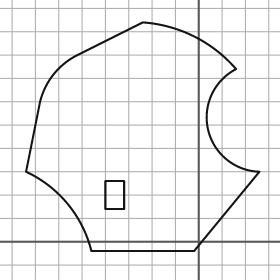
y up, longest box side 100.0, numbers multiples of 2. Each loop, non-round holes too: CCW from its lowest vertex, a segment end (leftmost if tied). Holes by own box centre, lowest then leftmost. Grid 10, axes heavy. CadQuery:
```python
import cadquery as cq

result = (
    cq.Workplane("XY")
    .moveTo(-46.0, -4.0)
    .lineTo(-2.0, -4.0)
    .lineTo(26.0, 30.0)
    .threePointArc((4.0, 48.0), (16.0, 74.0))
    .threePointArc((-2.0, 88.0), (-24.0, 94.0))
    .lineTo(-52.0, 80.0)
    .threePointArc((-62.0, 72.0), (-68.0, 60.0))
    .lineTo(-74.0, 30.0)
    .threePointArc((-56.0, 16.0), (-46.0, -4.0))
    .close()
    .moveTo(-40.0, 14.0)
    .lineTo(-32.0, 14.0)
    .lineTo(-32.0, 26.0)
    .lineTo(-40.0, 26.0)
    .close()
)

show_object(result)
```